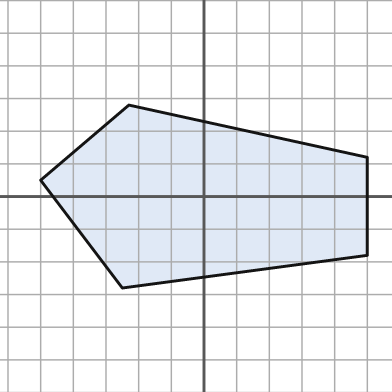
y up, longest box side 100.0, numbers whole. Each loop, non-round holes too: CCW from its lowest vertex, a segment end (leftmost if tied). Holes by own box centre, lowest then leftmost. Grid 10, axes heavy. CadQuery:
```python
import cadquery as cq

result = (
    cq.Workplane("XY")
    .moveTo(-25.0, -28.0)
    .lineTo(50.0, -18.0)
    .lineTo(50.0, 12.0)
    .lineTo(-23.0, 28.0)
    .lineTo(-50.0, 5.0)
    .close()
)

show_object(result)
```